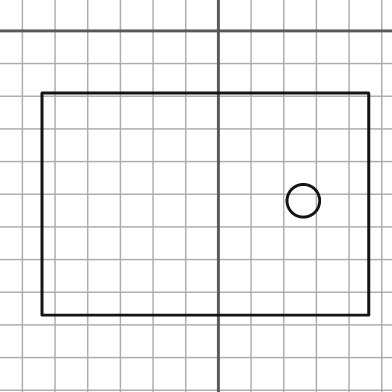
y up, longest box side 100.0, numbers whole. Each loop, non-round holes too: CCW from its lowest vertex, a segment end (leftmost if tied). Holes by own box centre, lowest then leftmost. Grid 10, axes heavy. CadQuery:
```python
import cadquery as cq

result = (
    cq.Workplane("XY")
    .moveTo(-54.0, -87.0)
    .lineTo(46.0, -87.0)
    .lineTo(46.0, -19.0)
    .lineTo(-54.0, -19.0)
    .close()
    .moveTo(26.0, -52.0)
    .circle(5.0)
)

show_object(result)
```